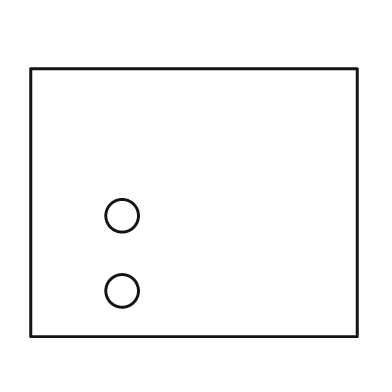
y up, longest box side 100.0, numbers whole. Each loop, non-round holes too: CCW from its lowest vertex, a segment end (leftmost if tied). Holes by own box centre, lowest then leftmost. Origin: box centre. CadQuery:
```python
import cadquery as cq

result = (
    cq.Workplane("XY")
    .moveTo(-50.0, -41.0)
    .lineTo(50.0, -41.0)
    .lineTo(50.0, 41.0)
    .lineTo(-50.0, 41.0)
    .close()
    .moveTo(-22.0, -27.0)
    .circle(5.0)
    .moveTo(-22.0, -4.0)
    .circle(5.0)
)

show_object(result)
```